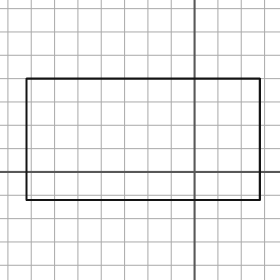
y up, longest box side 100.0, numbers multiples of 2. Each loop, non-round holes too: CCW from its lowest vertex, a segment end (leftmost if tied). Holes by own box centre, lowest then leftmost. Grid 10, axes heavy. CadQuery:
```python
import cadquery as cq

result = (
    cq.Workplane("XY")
    .moveTo(-72.0, -12.0)
    .lineTo(28.0, -12.0)
    .lineTo(28.0, 40.0)
    .lineTo(-72.0, 40.0)
    .close()
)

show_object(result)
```